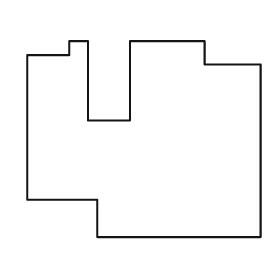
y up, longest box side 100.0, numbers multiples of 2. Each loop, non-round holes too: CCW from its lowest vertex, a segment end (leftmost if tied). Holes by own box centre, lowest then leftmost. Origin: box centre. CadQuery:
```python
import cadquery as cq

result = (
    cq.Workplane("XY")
    .moveTo(-20.0, -42.0)
    .lineTo(50.0, -42.0)
    .lineTo(50.0, 32.0)
    .lineTo(26.0, 32.0)
    .lineTo(26.0, 42.0)
    .lineTo(-6.0, 42.0)
    .lineTo(-6.0, 8.0)
    .lineTo(-24.0, 8.0)
    .lineTo(-24.0, 42.0)
    .lineTo(-32.0, 42.0)
    .lineTo(-32.0, 36.0)
    .lineTo(-50.0, 36.0)
    .lineTo(-50.0, -26.0)
    .lineTo(-20.0, -26.0)
    .close()
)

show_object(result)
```